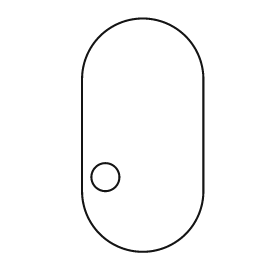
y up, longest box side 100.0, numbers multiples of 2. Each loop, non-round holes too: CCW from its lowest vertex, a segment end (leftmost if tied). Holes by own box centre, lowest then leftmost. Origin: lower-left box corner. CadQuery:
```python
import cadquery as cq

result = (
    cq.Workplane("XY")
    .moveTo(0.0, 26.0)
    .threePointArc((26.0, 0.0), (52.0, 26.0))
    .lineTo(52.0, 74.0)
    .threePointArc((26.0, 100.0), (0.0, 74.0))
    .close()
    .moveTo(10.0, 32.0)
    .circle(6.0)
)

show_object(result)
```